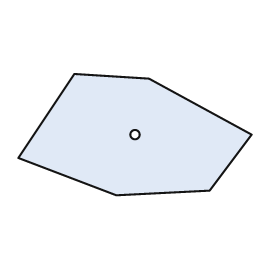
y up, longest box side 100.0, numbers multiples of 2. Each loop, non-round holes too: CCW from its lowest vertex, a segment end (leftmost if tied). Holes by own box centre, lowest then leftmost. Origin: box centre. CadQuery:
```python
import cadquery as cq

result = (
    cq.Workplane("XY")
    .moveTo(-8.0, -26.0)
    .lineTo(32.0, -24.0)
    .lineTo(50.0, 0.0)
    .lineTo(6.0, 24.0)
    .lineTo(-26.0, 26.0)
    .lineTo(-50.0, -10.0)
    .close()
    .moveTo(0.0, 0.0)
    .circle(2.0)
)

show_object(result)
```